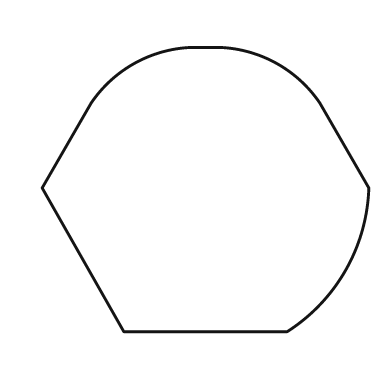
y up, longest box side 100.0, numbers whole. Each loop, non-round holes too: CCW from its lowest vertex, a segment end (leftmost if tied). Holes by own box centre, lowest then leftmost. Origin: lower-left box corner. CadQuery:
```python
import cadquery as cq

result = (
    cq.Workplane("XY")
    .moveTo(25.0, 0.0)
    .lineTo(75.0, 0.0)
    .threePointArc((93.0, 19.0), (100.0, 44.0))
    .lineTo(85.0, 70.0)
    .threePointArc((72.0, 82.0), (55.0, 87.0))
    .lineTo(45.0, 87.0)
    .threePointArc((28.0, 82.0), (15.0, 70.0))
    .lineTo(0.0, 44.0)
    .close()
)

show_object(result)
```